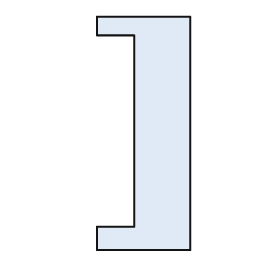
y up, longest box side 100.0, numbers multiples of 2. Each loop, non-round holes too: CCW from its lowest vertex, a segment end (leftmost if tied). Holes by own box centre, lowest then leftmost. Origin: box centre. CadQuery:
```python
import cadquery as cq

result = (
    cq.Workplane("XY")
    .moveTo(-20.0, -50.0)
    .lineTo(20.0, -50.0)
    .lineTo(20.0, 50.0)
    .lineTo(-20.0, 50.0)
    .lineTo(-20.0, 42.0)
    .lineTo(-4.0, 42.0)
    .lineTo(-4.0, -40.0)
    .lineTo(-20.0, -40.0)
    .close()
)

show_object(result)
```